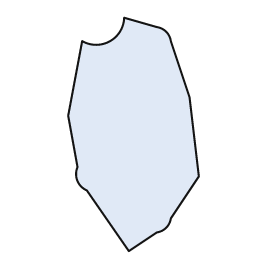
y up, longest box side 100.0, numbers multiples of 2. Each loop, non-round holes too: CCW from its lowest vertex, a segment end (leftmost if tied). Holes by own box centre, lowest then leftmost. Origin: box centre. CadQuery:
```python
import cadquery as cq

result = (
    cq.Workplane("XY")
    .moveTo(-2.0, -50.0)
    .lineTo(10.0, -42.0)
    .threePointArc((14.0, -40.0), (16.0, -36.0))
    .lineTo(28.0, -18.0)
    .lineTo(24.0, 16.0)
    .lineTo(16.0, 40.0)
    .threePointArc((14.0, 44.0), (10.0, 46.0))
    .lineTo(-4.0, 50.0)
    .threePointArc((-10.0, 40.0), (-22.0, 40.0))
    .lineTo(-28.0, 8.0)
    .lineTo(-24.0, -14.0)
    .threePointArc((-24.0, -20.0), (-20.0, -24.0))
    .close()
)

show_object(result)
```